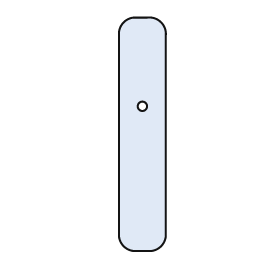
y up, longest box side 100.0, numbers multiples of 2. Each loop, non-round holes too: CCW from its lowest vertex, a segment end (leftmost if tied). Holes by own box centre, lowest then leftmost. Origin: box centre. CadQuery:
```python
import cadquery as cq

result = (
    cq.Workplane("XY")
    .moveTo(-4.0, -50.0)
    .lineTo(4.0, -50.0)
    .threePointArc((8.0, -48.0), (10.0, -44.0))
    .lineTo(10.0, 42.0)
    .threePointArc((8.0, 48.0), (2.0, 50.0))
    .lineTo(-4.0, 50.0)
    .threePointArc((-8.0, 48.0), (-10.0, 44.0))
    .lineTo(-10.0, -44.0)
    .threePointArc((-8.0, -48.0), (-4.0, -50.0))
    .close()
    .moveTo(0.0, 12.0)
    .circle(2.0)
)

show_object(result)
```